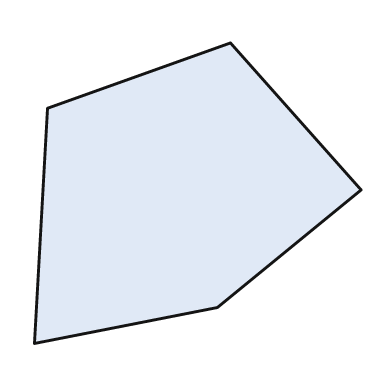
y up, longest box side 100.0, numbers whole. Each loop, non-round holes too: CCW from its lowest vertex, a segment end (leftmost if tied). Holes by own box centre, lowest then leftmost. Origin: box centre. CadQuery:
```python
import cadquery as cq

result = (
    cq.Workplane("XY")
    .moveTo(-50.0, -46.0)
    .lineTo(6.0, -35.0)
    .lineTo(50.0, 1.0)
    .lineTo(10.0, 46.0)
    .lineTo(-46.0, 26.0)
    .close()
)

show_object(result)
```